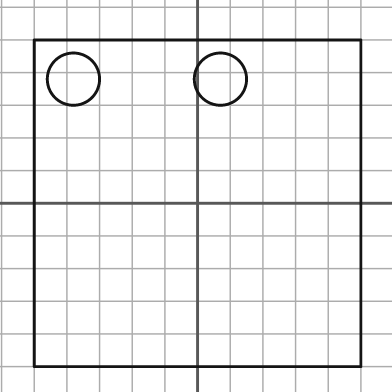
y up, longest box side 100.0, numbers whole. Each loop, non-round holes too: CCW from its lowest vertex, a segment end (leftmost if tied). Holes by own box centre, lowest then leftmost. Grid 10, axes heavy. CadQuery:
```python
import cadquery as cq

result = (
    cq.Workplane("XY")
    .moveTo(-50.0, -50.0)
    .lineTo(50.0, -50.0)
    .lineTo(50.0, 50.0)
    .lineTo(-50.0, 50.0)
    .close()
    .moveTo(-38.0, 38.0)
    .circle(8.0)
    .moveTo(7.0, 38.0)
    .circle(8.0)
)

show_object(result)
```